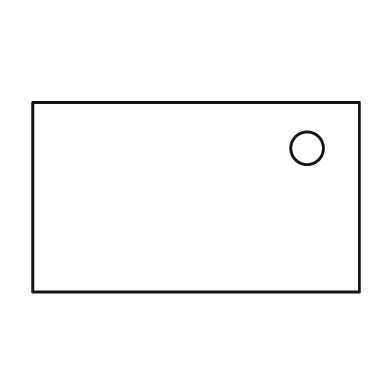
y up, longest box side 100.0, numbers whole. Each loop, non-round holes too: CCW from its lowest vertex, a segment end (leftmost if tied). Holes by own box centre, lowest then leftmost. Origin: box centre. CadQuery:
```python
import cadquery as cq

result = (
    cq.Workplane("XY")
    .moveTo(-50.0, -29.0)
    .lineTo(50.0, -29.0)
    .lineTo(50.0, 29.0)
    .lineTo(-50.0, 29.0)
    .close()
    .moveTo(34.0, 15.0)
    .circle(5.0)
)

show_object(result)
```